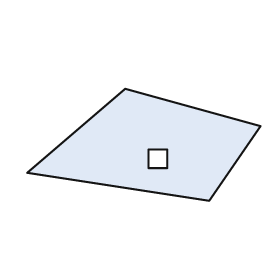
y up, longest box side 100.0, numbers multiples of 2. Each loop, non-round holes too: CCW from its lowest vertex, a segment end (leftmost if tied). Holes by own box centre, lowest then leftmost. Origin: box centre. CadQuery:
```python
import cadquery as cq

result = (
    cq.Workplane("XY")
    .moveTo(28.0, -24.0)
    .lineTo(50.0, 8.0)
    .lineTo(-8.0, 24.0)
    .lineTo(-50.0, -12.0)
    .close()
    .moveTo(2.0, -10.0)
    .lineTo(10.0, -10.0)
    .lineTo(10.0, -2.0)
    .lineTo(2.0, -2.0)
    .close()
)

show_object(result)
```